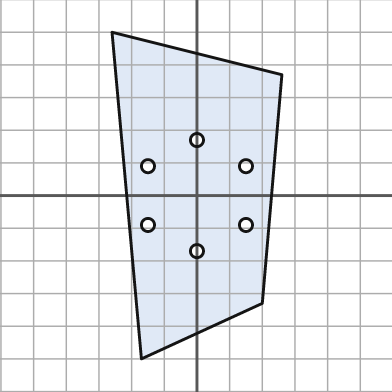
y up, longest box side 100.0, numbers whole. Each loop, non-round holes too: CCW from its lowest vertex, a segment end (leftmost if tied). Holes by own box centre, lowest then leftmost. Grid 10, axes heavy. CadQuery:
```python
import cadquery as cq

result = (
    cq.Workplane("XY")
    .moveTo(-17.0, -50.0)
    .lineTo(20.0, -33.0)
    .lineTo(26.0, 37.0)
    .lineTo(-26.0, 50.0)
    .close()
    .moveTo(0.0, -17.0)
    .circle(2.0)
    .moveTo(-15.0, -9.0)
    .circle(2.0)
    .moveTo(15.0, -9.0)
    .circle(2.0)
    .moveTo(-15.0, 9.0)
    .circle(2.0)
    .moveTo(15.0, 9.0)
    .circle(2.0)
    .moveTo(0.0, 17.0)
    .circle(2.0)
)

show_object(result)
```